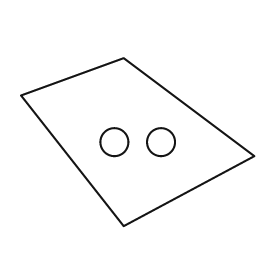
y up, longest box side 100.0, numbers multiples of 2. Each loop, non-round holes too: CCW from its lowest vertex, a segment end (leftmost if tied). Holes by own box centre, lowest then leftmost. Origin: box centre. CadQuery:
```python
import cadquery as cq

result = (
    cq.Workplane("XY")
    .moveTo(-6.0, -36.0)
    .lineTo(50.0, -6.0)
    .lineTo(-6.0, 36.0)
    .lineTo(-50.0, 20.0)
    .close()
    .moveTo(-10.0, 0.0)
    .circle(6.0)
    .moveTo(10.0, 0.0)
    .circle(6.0)
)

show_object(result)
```